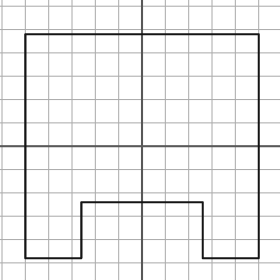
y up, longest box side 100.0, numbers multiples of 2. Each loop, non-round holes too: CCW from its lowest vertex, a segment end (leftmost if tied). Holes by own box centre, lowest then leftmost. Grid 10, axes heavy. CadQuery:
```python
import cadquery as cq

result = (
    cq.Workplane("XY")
    .moveTo(-50.0, -48.0)
    .lineTo(-26.0, -48.0)
    .lineTo(-26.0, -24.0)
    .lineTo(26.0, -24.0)
    .lineTo(26.0, -48.0)
    .lineTo(50.0, -48.0)
    .lineTo(50.0, 48.0)
    .lineTo(-50.0, 48.0)
    .close()
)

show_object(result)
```